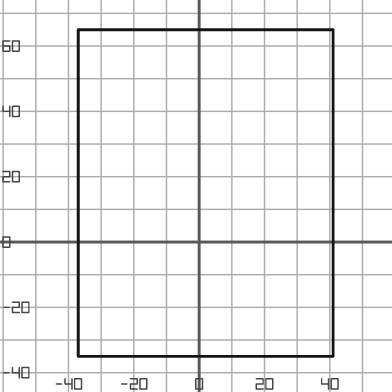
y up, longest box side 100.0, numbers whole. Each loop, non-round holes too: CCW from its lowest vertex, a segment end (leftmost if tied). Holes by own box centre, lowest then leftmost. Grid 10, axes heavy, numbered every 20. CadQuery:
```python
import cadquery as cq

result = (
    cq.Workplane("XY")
    .moveTo(-37.0, -35.0)
    .lineTo(41.0, -35.0)
    .lineTo(41.0, 65.0)
    .lineTo(-37.0, 65.0)
    .close()
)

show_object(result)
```